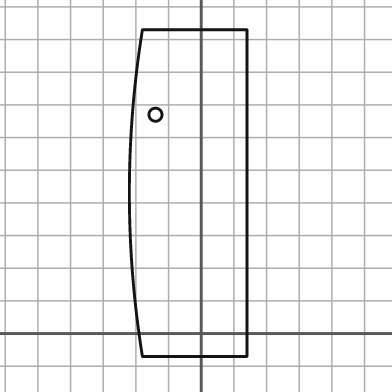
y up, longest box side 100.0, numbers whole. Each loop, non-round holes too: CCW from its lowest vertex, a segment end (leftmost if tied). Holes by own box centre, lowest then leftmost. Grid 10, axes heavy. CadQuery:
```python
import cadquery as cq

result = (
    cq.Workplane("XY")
    .moveTo(-18.0, -7.0)
    .lineTo(14.0, -7.0)
    .lineTo(14.0, 93.0)
    .lineTo(-18.0, 93.0)
    .threePointArc((-22.0, 43.0), (-18.0, -7.0))
    .close()
    .moveTo(-14.0, 67.0)
    .circle(2.0)
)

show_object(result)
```